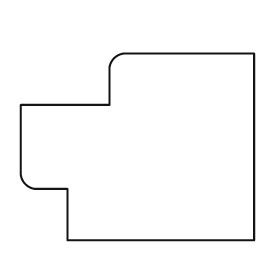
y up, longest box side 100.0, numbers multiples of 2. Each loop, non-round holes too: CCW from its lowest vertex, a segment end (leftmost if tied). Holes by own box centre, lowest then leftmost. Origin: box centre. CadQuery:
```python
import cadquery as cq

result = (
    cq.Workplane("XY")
    .moveTo(-30.0, -40.0)
    .lineTo(50.0, -40.0)
    .lineTo(50.0, 40.0)
    .lineTo(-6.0, 40.0)
    .threePointArc((-10.0, 38.0), (-12.0, 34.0))
    .lineTo(-12.0, 18.0)
    .lineTo(-50.0, 18.0)
    .lineTo(-50.0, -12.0)
    .threePointArc((-48.0, -16.0), (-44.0, -18.0))
    .lineTo(-30.0, -18.0)
    .close()
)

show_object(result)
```